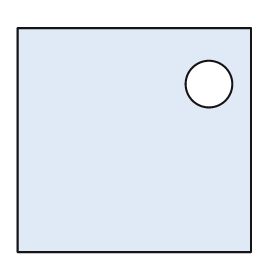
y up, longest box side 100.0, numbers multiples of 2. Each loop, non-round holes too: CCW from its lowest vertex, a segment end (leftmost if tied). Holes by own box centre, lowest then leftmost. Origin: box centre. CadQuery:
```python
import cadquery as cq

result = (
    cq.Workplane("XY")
    .moveTo(-50.0, -48.0)
    .lineTo(50.0, -48.0)
    .lineTo(50.0, 48.0)
    .lineTo(-50.0, 48.0)
    .close()
    .moveTo(32.0, 24.0)
    .circle(10.0)
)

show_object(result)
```